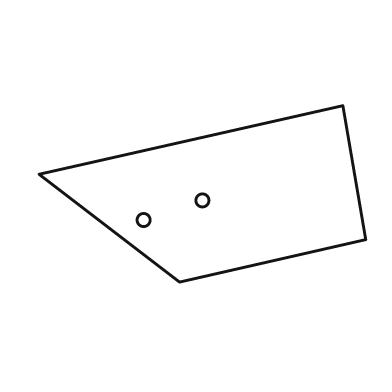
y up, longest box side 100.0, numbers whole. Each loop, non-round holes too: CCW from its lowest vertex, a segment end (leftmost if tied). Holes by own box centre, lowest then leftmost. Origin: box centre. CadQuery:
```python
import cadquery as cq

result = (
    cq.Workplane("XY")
    .moveTo(-7.0, -27.0)
    .lineTo(50.0, -14.0)
    .lineTo(43.0, 27.0)
    .lineTo(-50.0, 6.0)
    .close()
    .moveTo(-18.0, -8.0)
    .circle(2.0)
    .moveTo(0.0, -2.0)
    .circle(2.0)
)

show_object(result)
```